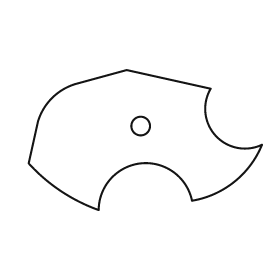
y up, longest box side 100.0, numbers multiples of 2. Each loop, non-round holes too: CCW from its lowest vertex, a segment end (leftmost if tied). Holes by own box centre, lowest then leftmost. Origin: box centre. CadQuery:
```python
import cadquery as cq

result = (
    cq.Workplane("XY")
    .moveTo(-20.0, -30.0)
    .threePointArc((-2.0, -10.0), (20.0, -26.0))
    .threePointArc((38.0, -18.0), (50.0, -2.0))
    .threePointArc((30.0, 2.0), (28.0, 22.0))
    .lineTo(-8.0, 30.0)
    .lineTo(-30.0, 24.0)
    .threePointArc((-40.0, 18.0), (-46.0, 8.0))
    .lineTo(-50.0, -10.0)
    .threePointArc((-36.0, -22.0), (-20.0, -30.0))
    .close()
    .moveTo(-2.0, 6.0)
    .circle(4.0)
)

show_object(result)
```